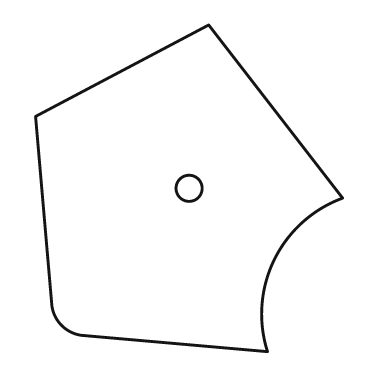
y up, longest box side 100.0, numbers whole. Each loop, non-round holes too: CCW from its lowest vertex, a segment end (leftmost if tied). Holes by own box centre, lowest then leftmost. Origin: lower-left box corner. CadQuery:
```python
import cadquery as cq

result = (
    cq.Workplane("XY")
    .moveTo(71.0, 0.0)
    .threePointArc((73.0, 28.0), (94.0, 47.0))
    .lineTo(53.0, 100.0)
    .lineTo(0.0, 72.0)
    .lineTo(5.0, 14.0)
    .threePointArc((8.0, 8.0), (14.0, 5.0))
    .close()
    .moveTo(47.0, 50.0)
    .circle(4.0)
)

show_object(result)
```